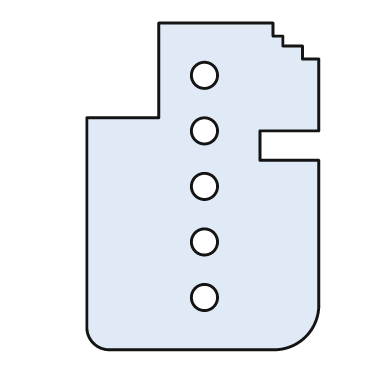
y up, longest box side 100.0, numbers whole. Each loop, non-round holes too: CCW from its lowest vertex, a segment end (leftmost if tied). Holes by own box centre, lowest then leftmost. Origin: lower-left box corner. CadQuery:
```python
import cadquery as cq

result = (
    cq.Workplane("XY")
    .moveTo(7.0, 0.0)
    .lineTo(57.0, 0.0)
    .threePointArc((67.0, 4.0), (71.0, 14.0))
    .lineTo(71.0, 58.0)
    .lineTo(53.0, 58.0)
    .lineTo(53.0, 67.0)
    .lineTo(71.0, 67.0)
    .lineTo(71.0, 89.0)
    .lineTo(66.0, 89.0)
    .lineTo(66.0, 93.0)
    .lineTo(60.0, 93.0)
    .lineTo(60.0, 96.0)
    .lineTo(57.0, 96.0)
    .lineTo(57.0, 100.0)
    .lineTo(22.0, 100.0)
    .lineTo(22.0, 71.0)
    .lineTo(0.0, 71.0)
    .lineTo(0.0, 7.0)
    .threePointArc((2.0, 2.0), (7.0, 0.0))
    .close()
    .moveTo(36.0, 16.0)
    .circle(4.0)
    .moveTo(36.0, 33.0)
    .circle(4.0)
    .moveTo(36.0, 50.0)
    .circle(4.0)
    .moveTo(36.0, 67.0)
    .circle(4.0)
    .moveTo(36.0, 84.0)
    .circle(4.0)
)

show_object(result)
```